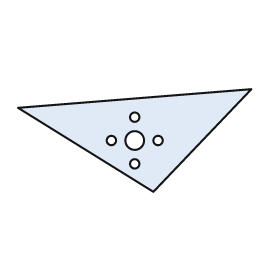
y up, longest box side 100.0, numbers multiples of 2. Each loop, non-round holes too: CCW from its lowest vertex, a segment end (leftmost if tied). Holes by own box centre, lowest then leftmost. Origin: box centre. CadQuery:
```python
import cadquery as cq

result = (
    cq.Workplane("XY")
    .moveTo(8.0, -22.0)
    .lineTo(50.0, 22.0)
    .lineTo(-50.0, 14.0)
    .close()
    .moveTo(0.0, -10.0)
    .circle(2.0)
    .moveTo(-10.0, 0.0)
    .circle(2.0)
    .moveTo(0.0, 0.0)
    .circle(4.0)
    .moveTo(10.0, 0.0)
    .circle(2.0)
    .moveTo(0.0, 10.0)
    .circle(2.0)
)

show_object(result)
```